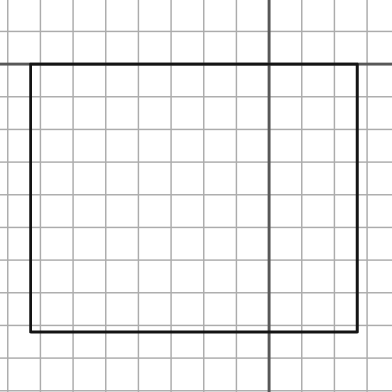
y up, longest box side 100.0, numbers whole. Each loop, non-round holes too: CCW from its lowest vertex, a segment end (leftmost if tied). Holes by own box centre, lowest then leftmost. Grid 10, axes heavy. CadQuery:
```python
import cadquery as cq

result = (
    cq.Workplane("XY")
    .moveTo(-73.0, -82.0)
    .lineTo(27.0, -82.0)
    .lineTo(27.0, 0.0)
    .lineTo(-73.0, 0.0)
    .close()
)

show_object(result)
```